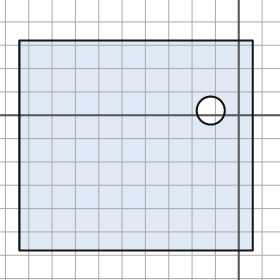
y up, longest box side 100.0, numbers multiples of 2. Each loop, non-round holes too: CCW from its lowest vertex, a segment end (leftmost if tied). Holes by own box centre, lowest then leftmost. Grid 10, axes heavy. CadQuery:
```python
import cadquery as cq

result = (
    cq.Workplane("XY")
    .moveTo(-94.0, -58.0)
    .lineTo(6.0, -58.0)
    .lineTo(6.0, 32.0)
    .lineTo(-94.0, 32.0)
    .close()
    .moveTo(-12.0, 2.0)
    .circle(6.0)
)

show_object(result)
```